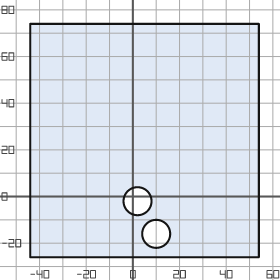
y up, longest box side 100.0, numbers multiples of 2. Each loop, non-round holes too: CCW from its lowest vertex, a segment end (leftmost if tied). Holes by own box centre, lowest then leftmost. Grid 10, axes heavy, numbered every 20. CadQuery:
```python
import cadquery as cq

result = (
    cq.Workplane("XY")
    .moveTo(-44.0, -26.0)
    .lineTo(54.0, -26.0)
    .lineTo(54.0, 74.0)
    .lineTo(-44.0, 74.0)
    .close()
    .moveTo(10.0, -16.0)
    .circle(6.0)
    .moveTo(2.0, -2.0)
    .circle(6.0)
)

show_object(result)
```